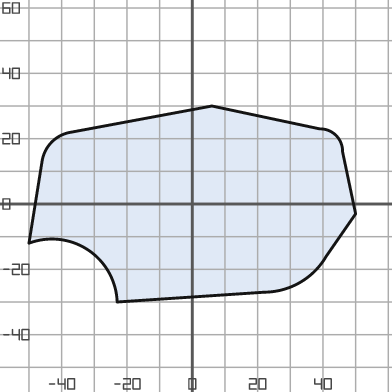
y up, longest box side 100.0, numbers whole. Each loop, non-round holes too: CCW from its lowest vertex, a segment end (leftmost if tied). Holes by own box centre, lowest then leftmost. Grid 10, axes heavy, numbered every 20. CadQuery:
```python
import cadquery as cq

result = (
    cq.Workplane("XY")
    .moveTo(-23.0, -30.0)
    .lineTo(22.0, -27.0)
    .threePointArc((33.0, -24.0), (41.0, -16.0))
    .lineTo(50.0, -3.0)
    .lineTo(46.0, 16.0)
    .threePointArc((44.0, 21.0), (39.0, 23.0))
    .lineTo(6.0, 30.0)
    .lineTo(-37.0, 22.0)
    .threePointArc((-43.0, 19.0), (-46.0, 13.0))
    .lineTo(-50.0, -12.0)
    .threePointArc((-32.0, -14.0), (-23.0, -30.0))
    .close()
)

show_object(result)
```